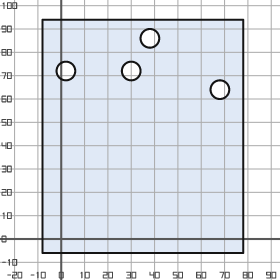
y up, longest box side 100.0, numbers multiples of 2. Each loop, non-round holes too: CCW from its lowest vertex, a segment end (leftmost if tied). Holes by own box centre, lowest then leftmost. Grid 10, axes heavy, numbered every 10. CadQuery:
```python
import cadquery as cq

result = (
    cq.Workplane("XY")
    .moveTo(-8.0, -6.0)
    .lineTo(78.0, -6.0)
    .lineTo(78.0, 94.0)
    .lineTo(-8.0, 94.0)
    .close()
    .moveTo(68.0, 64.0)
    .circle(4.0)
    .moveTo(2.0, 72.0)
    .circle(4.0)
    .moveTo(30.0, 72.0)
    .circle(4.0)
    .moveTo(38.0, 86.0)
    .circle(4.0)
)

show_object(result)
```